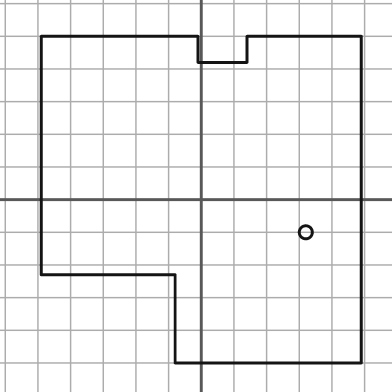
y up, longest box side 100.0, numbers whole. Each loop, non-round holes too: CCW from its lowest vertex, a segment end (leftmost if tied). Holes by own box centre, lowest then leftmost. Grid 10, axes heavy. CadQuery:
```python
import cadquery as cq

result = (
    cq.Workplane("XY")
    .moveTo(-8.0, -50.0)
    .lineTo(49.0, -50.0)
    .lineTo(49.0, 50.0)
    .lineTo(14.0, 50.0)
    .lineTo(14.0, 42.0)
    .lineTo(-1.0, 42.0)
    .lineTo(-1.0, 50.0)
    .lineTo(-49.0, 50.0)
    .lineTo(-49.0, -23.0)
    .lineTo(-8.0, -23.0)
    .close()
    .moveTo(32.0, -10.0)
    .circle(2.0)
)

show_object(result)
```